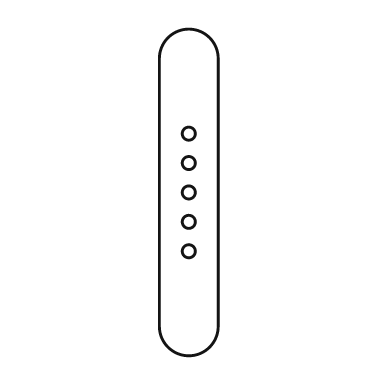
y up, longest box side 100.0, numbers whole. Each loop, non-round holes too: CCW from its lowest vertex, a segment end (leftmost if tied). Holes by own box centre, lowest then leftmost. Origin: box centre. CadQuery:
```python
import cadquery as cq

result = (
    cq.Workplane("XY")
    .moveTo(-9.0, -41.0)
    .threePointArc((0.0, -50.0), (9.0, -41.0))
    .lineTo(9.0, 41.0)
    .threePointArc((0.0, 50.0), (-9.0, 41.0))
    .close()
    .moveTo(0.0, -18.0)
    .circle(2.0)
    .moveTo(0.0, -9.0)
    .circle(2.0)
    .moveTo(0.0, 0.0)
    .circle(2.0)
    .moveTo(0.0, 9.0)
    .circle(2.0)
    .moveTo(0.0, 18.0)
    .circle(2.0)
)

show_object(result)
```